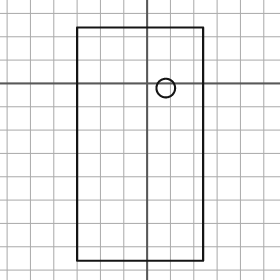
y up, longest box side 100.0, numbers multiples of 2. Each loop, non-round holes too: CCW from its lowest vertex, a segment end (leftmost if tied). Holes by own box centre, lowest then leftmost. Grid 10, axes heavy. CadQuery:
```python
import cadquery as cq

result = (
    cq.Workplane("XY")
    .moveTo(-30.0, -76.0)
    .lineTo(24.0, -76.0)
    .lineTo(24.0, 24.0)
    .lineTo(-30.0, 24.0)
    .close()
    .moveTo(8.0, -2.0)
    .circle(4.0)
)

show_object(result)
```